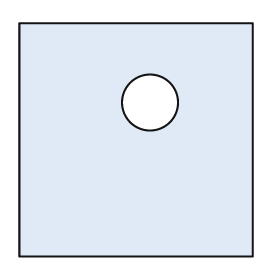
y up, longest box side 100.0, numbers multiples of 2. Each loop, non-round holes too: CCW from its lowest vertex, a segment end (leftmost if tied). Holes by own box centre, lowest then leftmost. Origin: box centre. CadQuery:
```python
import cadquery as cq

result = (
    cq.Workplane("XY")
    .moveTo(-50.0, -50.0)
    .lineTo(50.0, -50.0)
    .lineTo(50.0, 50.0)
    .lineTo(-50.0, 50.0)
    .close()
    .moveTo(6.0, 16.0)
    .circle(12.0)
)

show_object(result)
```